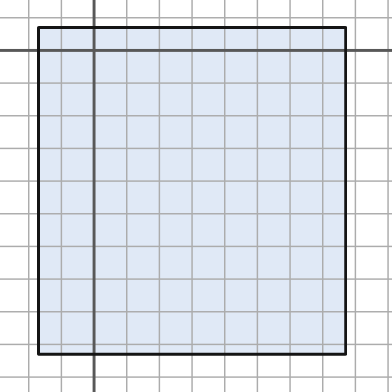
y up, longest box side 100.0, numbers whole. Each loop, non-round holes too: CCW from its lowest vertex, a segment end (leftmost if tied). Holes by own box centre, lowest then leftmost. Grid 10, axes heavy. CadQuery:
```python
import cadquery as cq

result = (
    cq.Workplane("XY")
    .moveTo(-17.0, -93.0)
    .lineTo(77.0, -93.0)
    .lineTo(77.0, 7.0)
    .lineTo(-17.0, 7.0)
    .close()
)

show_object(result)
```